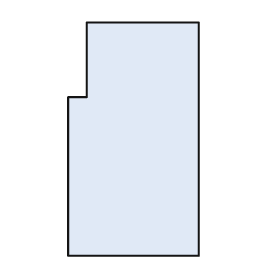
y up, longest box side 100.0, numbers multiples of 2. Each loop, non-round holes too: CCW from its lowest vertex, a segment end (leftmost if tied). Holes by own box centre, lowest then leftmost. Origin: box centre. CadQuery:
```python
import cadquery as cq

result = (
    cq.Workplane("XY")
    .moveTo(-28.0, -50.0)
    .lineTo(28.0, -50.0)
    .lineTo(28.0, 50.0)
    .lineTo(-20.0, 50.0)
    .lineTo(-20.0, 18.0)
    .lineTo(-28.0, 18.0)
    .close()
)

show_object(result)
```